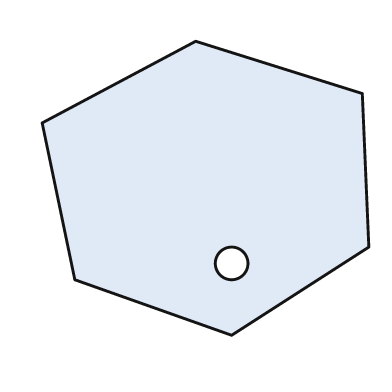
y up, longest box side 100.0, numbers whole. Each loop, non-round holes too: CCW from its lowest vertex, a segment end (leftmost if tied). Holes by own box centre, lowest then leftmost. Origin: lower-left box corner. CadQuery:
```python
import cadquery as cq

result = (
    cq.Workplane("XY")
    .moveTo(58.0, 0.0)
    .lineTo(100.0, 27.0)
    .lineTo(98.0, 74.0)
    .lineTo(47.0, 90.0)
    .lineTo(0.0, 65.0)
    .lineTo(10.0, 17.0)
    .close()
    .moveTo(58.0, 22.0)
    .circle(5.0)
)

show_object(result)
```